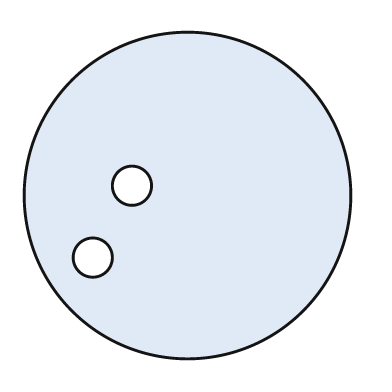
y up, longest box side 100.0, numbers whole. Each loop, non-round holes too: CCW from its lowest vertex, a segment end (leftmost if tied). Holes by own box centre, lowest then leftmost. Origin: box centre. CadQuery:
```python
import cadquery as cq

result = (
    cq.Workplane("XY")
    .moveTo(0.0, 0.0)
    .circle(50.0)
    .moveTo(-29.0, -19.0)
    .circle(6.0)
    .moveTo(-17.0, 3.0)
    .circle(6.0)
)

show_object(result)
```